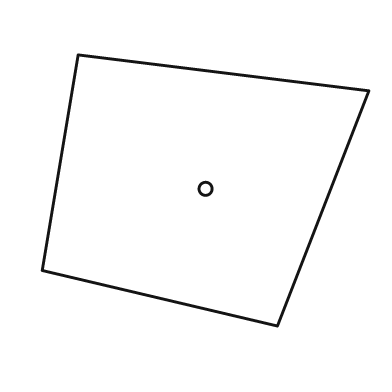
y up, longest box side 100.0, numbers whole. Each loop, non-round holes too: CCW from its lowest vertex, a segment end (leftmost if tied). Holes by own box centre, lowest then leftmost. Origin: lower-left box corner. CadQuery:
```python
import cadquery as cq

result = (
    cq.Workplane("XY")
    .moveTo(72.0, 0.0)
    .lineTo(100.0, 72.0)
    .lineTo(11.0, 83.0)
    .lineTo(0.0, 17.0)
    .close()
    .moveTo(50.0, 42.0)
    .circle(2.0)
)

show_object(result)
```